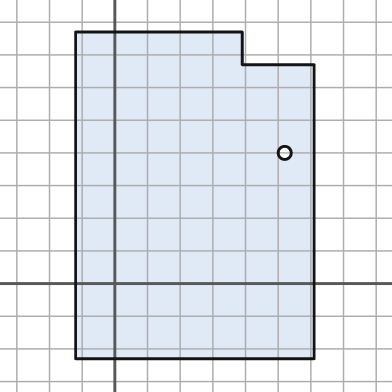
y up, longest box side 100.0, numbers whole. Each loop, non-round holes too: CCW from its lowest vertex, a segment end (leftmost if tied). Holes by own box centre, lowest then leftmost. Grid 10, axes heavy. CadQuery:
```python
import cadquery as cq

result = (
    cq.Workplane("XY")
    .moveTo(-12.0, -23.0)
    .lineTo(61.0, -23.0)
    .lineTo(61.0, 67.0)
    .lineTo(39.0, 67.0)
    .lineTo(39.0, 77.0)
    .lineTo(-12.0, 77.0)
    .close()
    .moveTo(52.0, 40.0)
    .circle(2.0)
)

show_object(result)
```